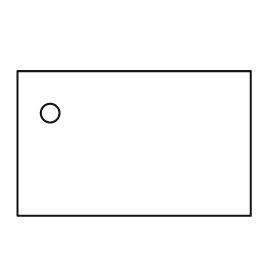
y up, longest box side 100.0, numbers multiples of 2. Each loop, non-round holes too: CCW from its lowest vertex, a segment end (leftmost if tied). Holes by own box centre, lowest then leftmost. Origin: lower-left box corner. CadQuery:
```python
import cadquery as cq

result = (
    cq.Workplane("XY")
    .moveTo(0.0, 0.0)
    .lineTo(100.0, 0.0)
    .lineTo(100.0, 62.0)
    .lineTo(0.0, 62.0)
    .close()
    .moveTo(14.0, 44.0)
    .circle(4.0)
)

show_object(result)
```